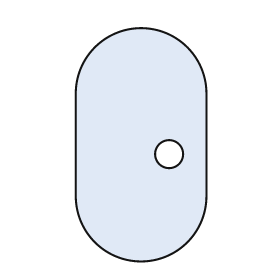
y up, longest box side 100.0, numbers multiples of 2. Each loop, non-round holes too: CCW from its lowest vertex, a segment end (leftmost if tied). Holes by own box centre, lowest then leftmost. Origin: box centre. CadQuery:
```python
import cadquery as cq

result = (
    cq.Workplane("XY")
    .moveTo(-28.0, -22.0)
    .threePointArc((0.0, -50.0), (28.0, -22.0))
    .lineTo(28.0, 22.0)
    .threePointArc((0.0, 50.0), (-28.0, 22.0))
    .close()
    .moveTo(12.0, -4.0)
    .circle(6.0)
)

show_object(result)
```